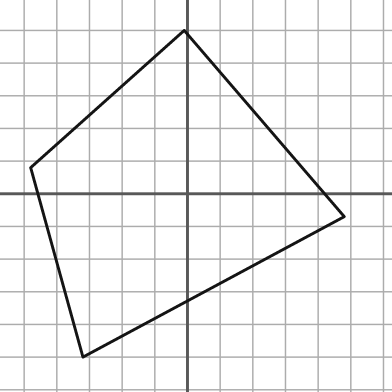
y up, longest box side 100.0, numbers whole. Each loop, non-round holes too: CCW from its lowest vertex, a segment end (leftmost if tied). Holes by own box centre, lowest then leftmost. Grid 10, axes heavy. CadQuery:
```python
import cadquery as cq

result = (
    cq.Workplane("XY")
    .moveTo(-32.0, -50.0)
    .lineTo(48.0, -7.0)
    .lineTo(-1.0, 50.0)
    .lineTo(-48.0, 8.0)
    .close()
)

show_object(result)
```